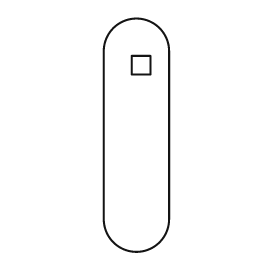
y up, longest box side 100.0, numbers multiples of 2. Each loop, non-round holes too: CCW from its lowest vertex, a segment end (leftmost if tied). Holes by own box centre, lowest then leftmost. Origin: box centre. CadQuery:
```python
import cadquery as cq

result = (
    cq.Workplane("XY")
    .moveTo(-14.0, -36.0)
    .threePointArc((0.0, -50.0), (14.0, -36.0))
    .lineTo(14.0, 36.0)
    .threePointArc((0.0, 50.0), (-14.0, 36.0))
    .close()
    .moveTo(-2.0, 26.0)
    .lineTo(6.0, 26.0)
    .lineTo(6.0, 34.0)
    .lineTo(-2.0, 34.0)
    .close()
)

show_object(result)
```